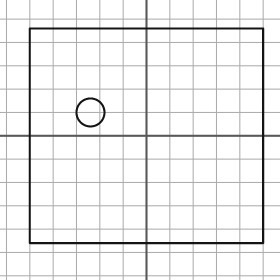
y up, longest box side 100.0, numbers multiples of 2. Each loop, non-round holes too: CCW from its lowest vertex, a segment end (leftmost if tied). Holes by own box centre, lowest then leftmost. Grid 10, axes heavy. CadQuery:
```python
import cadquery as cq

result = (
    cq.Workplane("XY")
    .moveTo(-50.0, -46.0)
    .lineTo(50.0, -46.0)
    .lineTo(50.0, 46.0)
    .lineTo(-50.0, 46.0)
    .close()
    .moveTo(-24.0, 10.0)
    .circle(6.0)
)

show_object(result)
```